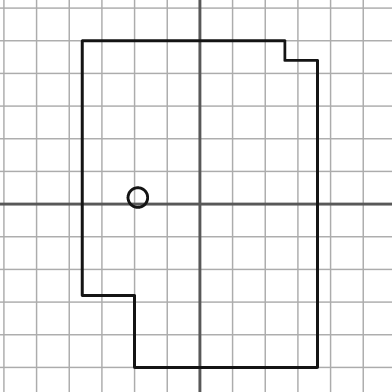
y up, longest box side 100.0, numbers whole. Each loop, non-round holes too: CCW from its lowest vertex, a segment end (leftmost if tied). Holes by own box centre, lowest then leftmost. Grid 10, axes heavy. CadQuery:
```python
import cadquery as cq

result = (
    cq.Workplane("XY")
    .moveTo(-20.0, -50.0)
    .lineTo(36.0, -50.0)
    .lineTo(36.0, 44.0)
    .lineTo(26.0, 44.0)
    .lineTo(26.0, 50.0)
    .lineTo(-36.0, 50.0)
    .lineTo(-36.0, -28.0)
    .lineTo(-20.0, -28.0)
    .close()
    .moveTo(-19.0, 2.0)
    .circle(3.0)
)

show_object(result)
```